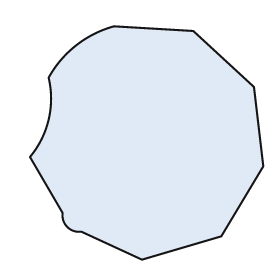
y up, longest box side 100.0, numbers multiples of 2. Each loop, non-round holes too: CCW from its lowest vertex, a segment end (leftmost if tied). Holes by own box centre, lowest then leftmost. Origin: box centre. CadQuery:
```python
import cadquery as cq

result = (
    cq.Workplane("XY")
    .moveTo(-2.0, -50.0)
    .lineTo(32.0, -40.0)
    .lineTo(50.0, -10.0)
    .lineTo(46.0, 24.0)
    .lineTo(20.0, 48.0)
    .lineTo(-14.0, 50.0)
    .threePointArc((-30.0, 42.0), (-42.0, 28.0))
    .threePointArc((-42.0, 10.0), (-50.0, -6.0))
    .lineTo(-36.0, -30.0)
    .threePointArc((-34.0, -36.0), (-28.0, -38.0))
    .close()
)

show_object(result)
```